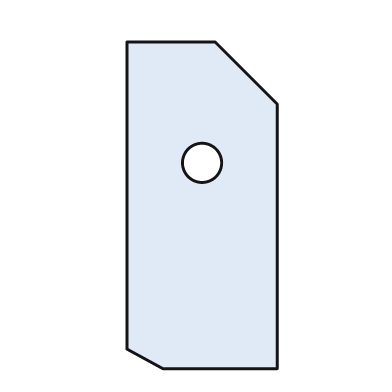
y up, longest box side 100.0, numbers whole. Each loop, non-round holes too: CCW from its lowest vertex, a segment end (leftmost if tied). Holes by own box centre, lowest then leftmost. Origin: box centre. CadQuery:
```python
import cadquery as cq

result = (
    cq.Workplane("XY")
    .moveTo(-12.0, -50.0)
    .lineTo(23.0, -50.0)
    .lineTo(23.0, 31.0)
    .lineTo(4.0, 50.0)
    .lineTo(-23.0, 50.0)
    .lineTo(-23.0, -44.0)
    .close()
    .moveTo(0.0, 13.0)
    .circle(6.0)
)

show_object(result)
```